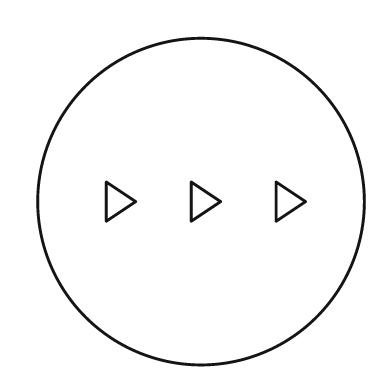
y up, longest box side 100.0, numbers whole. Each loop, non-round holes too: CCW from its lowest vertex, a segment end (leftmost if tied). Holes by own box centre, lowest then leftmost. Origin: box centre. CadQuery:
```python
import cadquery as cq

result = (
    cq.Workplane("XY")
    .moveTo(0.0, 0.0)
    .circle(50.0)
    .moveTo(-29.0, -6.0)
    .lineTo(-20.0, 0.0)
    .lineTo(-29.0, 6.0)
    .close()
    .moveTo(-3.0, -6.0)
    .lineTo(6.0, 0.0)
    .lineTo(-3.0, 6.0)
    .close()
    .moveTo(23.0, -6.0)
    .lineTo(32.0, 0.0)
    .lineTo(23.0, 6.0)
    .close()
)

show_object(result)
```